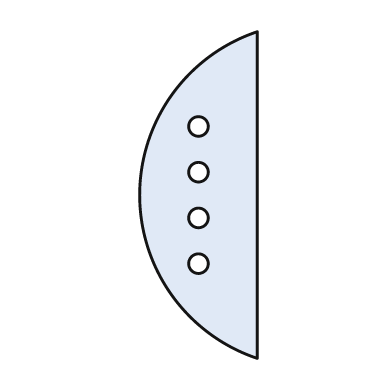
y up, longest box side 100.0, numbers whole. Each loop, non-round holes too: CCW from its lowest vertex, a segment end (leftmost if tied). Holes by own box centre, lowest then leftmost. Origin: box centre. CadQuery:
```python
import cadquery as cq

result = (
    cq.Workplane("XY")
    .moveTo(18.0, -50.0)
    .lineTo(18.0, 50.0)
    .threePointArc((-18.0, 0.0), (18.0, -50.0))
    .close()
    .moveTo(0.0, -21.0)
    .circle(3.0)
    .moveTo(0.0, -7.0)
    .circle(3.0)
    .moveTo(0.0, 7.0)
    .circle(3.0)
    .moveTo(0.0, 21.0)
    .circle(3.0)
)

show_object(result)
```